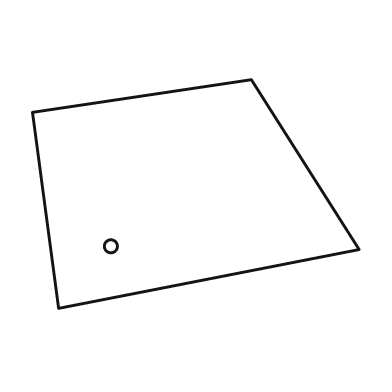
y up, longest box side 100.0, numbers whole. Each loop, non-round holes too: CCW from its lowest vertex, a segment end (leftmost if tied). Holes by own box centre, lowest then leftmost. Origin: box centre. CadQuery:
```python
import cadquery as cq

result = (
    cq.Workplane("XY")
    .moveTo(-42.0, -35.0)
    .lineTo(50.0, -17.0)
    .lineTo(17.0, 35.0)
    .lineTo(-50.0, 25.0)
    .close()
    .moveTo(-26.0, -16.0)
    .circle(2.0)
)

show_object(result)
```